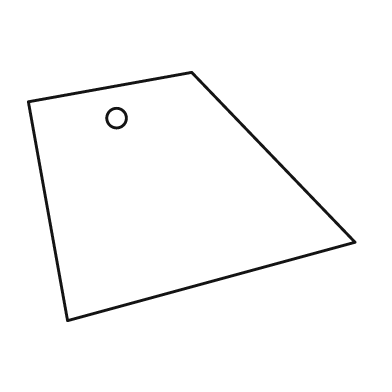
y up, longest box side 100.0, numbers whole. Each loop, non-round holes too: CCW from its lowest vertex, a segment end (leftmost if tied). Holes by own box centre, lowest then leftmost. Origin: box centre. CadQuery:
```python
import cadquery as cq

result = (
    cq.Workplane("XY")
    .moveTo(-38.0, -38.0)
    .lineTo(50.0, -14.0)
    .lineTo(0.0, 38.0)
    .lineTo(-50.0, 29.0)
    .close()
    .moveTo(-23.0, 24.0)
    .circle(3.0)
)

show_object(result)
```